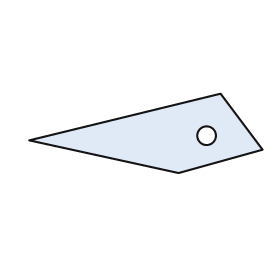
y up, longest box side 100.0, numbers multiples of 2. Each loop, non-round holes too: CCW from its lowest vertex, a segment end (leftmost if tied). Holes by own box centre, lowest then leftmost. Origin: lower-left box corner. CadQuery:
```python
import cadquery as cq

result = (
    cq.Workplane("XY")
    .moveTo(64.0, 0.0)
    .lineTo(100.0, 10.0)
    .lineTo(82.0, 34.0)
    .lineTo(0.0, 14.0)
    .close()
    .moveTo(76.0, 16.0)
    .circle(4.0)
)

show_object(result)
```